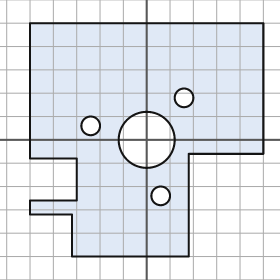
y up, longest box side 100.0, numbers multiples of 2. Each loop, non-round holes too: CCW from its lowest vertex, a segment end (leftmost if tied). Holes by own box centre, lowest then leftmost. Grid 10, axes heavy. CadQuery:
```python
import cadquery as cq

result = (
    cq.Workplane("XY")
    .moveTo(-32.0, -50.0)
    .lineTo(18.0, -50.0)
    .lineTo(18.0, -6.0)
    .lineTo(50.0, -6.0)
    .lineTo(50.0, 50.0)
    .lineTo(-50.0, 50.0)
    .lineTo(-50.0, -8.0)
    .lineTo(-30.0, -8.0)
    .lineTo(-30.0, -26.0)
    .lineTo(-50.0, -26.0)
    .lineTo(-50.0, -32.0)
    .lineTo(-32.0, -32.0)
    .close()
    .moveTo(6.0, -24.0)
    .circle(4.0)
    .moveTo(0.0, 0.0)
    .circle(12.0)
    .moveTo(-24.0, 6.0)
    .circle(4.0)
    .moveTo(16.0, 18.0)
    .circle(4.0)
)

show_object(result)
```